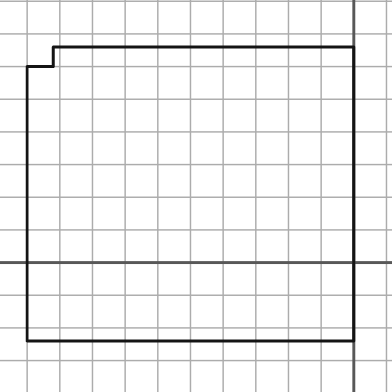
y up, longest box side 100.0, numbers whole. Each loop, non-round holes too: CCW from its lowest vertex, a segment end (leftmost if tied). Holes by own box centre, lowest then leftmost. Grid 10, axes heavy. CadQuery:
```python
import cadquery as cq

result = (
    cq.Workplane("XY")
    .moveTo(-100.0, -24.0)
    .lineTo(0.0, -24.0)
    .lineTo(0.0, 66.0)
    .lineTo(-92.0, 66.0)
    .lineTo(-92.0, 60.0)
    .lineTo(-100.0, 60.0)
    .close()
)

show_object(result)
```